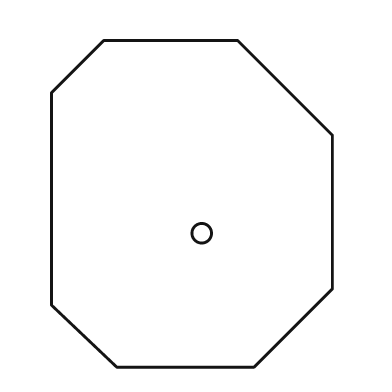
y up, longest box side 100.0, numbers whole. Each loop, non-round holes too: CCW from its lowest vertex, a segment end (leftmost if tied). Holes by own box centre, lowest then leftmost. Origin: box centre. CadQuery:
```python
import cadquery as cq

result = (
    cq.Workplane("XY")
    .moveTo(-23.0, -50.0)
    .lineTo(19.0, -50.0)
    .lineTo(43.0, -26.0)
    .lineTo(43.0, 21.0)
    .lineTo(14.0, 50.0)
    .lineTo(-27.0, 50.0)
    .lineTo(-43.0, 34.0)
    .lineTo(-43.0, -31.0)
    .close()
    .moveTo(3.0, -9.0)
    .circle(3.0)
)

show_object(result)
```